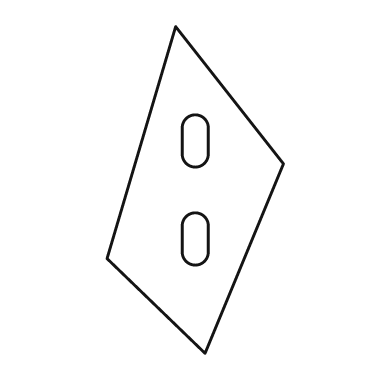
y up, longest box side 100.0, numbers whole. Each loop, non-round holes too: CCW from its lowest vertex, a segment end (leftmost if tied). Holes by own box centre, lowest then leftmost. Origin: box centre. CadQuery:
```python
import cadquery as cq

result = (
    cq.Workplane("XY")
    .moveTo(3.0, -50.0)
    .lineTo(27.0, 8.0)
    .lineTo(-6.0, 50.0)
    .lineTo(-27.0, -21.0)
    .close()
    .moveTo(-4.0, -19.0)
    .threePointArc((0.0, -23.0), (4.0, -19.0))
    .lineTo(4.0, -11.0)
    .threePointArc((0.0, -7.0), (-4.0, -11.0))
    .close()
    .moveTo(-4.0, 11.0)
    .threePointArc((0.0, 7.0), (4.0, 11.0))
    .lineTo(4.0, 19.0)
    .threePointArc((0.0, 23.0), (-4.0, 19.0))
    .close()
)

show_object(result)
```